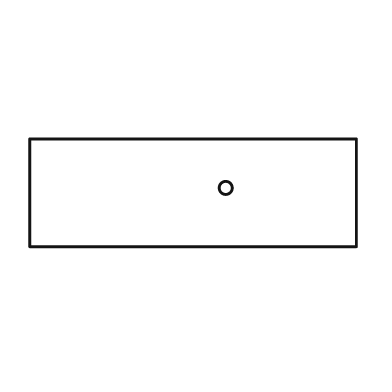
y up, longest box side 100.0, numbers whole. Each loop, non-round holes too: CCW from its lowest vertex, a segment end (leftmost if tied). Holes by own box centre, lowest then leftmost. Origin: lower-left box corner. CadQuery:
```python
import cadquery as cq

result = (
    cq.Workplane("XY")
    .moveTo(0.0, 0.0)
    .lineTo(100.0, 0.0)
    .lineTo(100.0, 33.0)
    .lineTo(0.0, 33.0)
    .close()
    .moveTo(60.0, 18.0)
    .circle(2.0)
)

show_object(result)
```